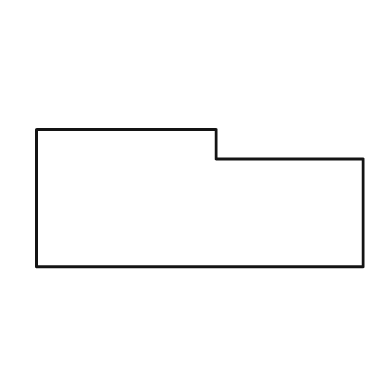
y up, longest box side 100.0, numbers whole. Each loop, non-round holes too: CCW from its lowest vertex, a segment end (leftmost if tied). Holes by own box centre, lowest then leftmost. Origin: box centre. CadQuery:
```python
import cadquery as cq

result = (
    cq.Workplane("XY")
    .moveTo(-50.0, -21.0)
    .lineTo(50.0, -21.0)
    .lineTo(50.0, 12.0)
    .lineTo(5.0, 12.0)
    .lineTo(5.0, 21.0)
    .lineTo(-50.0, 21.0)
    .close()
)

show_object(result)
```